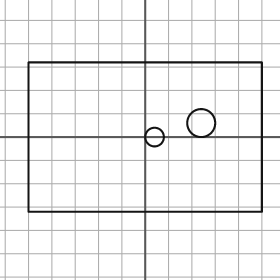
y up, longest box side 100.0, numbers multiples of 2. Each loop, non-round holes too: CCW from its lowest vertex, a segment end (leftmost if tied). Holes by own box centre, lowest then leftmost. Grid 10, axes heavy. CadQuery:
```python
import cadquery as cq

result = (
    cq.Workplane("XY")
    .moveTo(-50.0, -32.0)
    .lineTo(50.0, -32.0)
    .lineTo(50.0, 32.0)
    .lineTo(-50.0, 32.0)
    .close()
    .moveTo(4.0, 0.0)
    .circle(4.0)
    .moveTo(24.0, 6.0)
    .circle(6.0)
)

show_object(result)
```